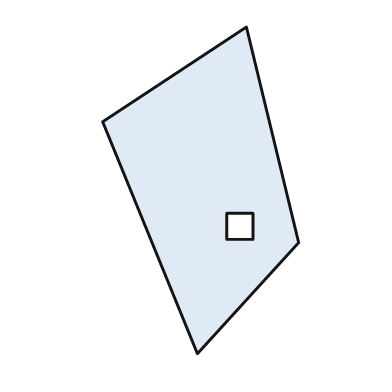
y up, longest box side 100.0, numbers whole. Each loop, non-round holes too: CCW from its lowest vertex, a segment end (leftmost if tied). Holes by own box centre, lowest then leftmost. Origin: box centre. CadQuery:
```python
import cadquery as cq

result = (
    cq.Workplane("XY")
    .moveTo(-1.0, -50.0)
    .lineTo(30.0, -16.0)
    .lineTo(14.0, 50.0)
    .lineTo(-30.0, 21.0)
    .close()
    .moveTo(8.0, -15.0)
    .lineTo(16.0, -15.0)
    .lineTo(16.0, -7.0)
    .lineTo(8.0, -7.0)
    .close()
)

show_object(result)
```